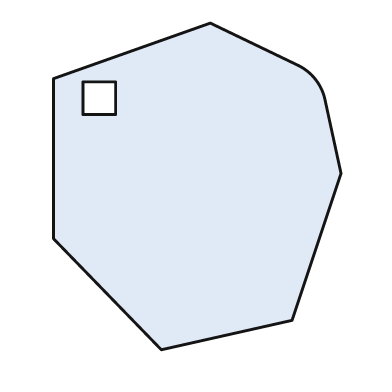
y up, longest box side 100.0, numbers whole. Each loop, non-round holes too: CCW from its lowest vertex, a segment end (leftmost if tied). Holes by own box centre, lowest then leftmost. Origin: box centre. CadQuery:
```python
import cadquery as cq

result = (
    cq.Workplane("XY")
    .moveTo(-11.0, -50.0)
    .lineTo(29.0, -41.0)
    .lineTo(44.0, 4.0)
    .lineTo(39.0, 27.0)
    .threePointArc((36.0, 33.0), (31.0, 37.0))
    .lineTo(4.0, 50.0)
    .lineTo(-44.0, 33.0)
    .lineTo(-44.0, -16.0)
    .close()
    .moveTo(-35.0, 22.0)
    .lineTo(-25.0, 22.0)
    .lineTo(-25.0, 32.0)
    .lineTo(-35.0, 32.0)
    .close()
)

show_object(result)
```